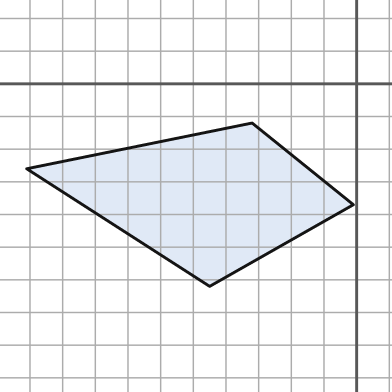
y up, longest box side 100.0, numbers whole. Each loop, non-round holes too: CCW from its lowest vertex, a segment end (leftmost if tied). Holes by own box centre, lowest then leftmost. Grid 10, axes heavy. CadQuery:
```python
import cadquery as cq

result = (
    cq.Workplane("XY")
    .moveTo(-45.0, -62.0)
    .lineTo(-1.0, -37.0)
    .lineTo(-32.0, -12.0)
    .lineTo(-101.0, -26.0)
    .close()
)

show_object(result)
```